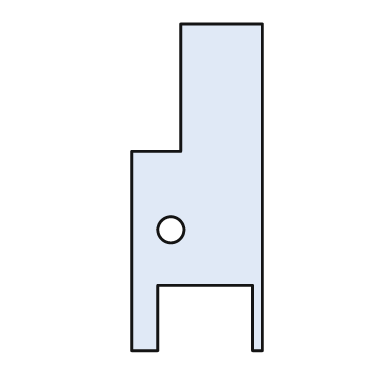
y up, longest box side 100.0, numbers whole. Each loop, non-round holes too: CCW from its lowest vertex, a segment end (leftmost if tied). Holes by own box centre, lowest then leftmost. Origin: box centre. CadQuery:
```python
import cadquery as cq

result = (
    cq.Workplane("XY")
    .moveTo(-20.0, -50.0)
    .lineTo(-12.0, -50.0)
    .lineTo(-12.0, -30.0)
    .lineTo(17.0, -30.0)
    .lineTo(17.0, -50.0)
    .lineTo(20.0, -50.0)
    .lineTo(20.0, 50.0)
    .lineTo(-5.0, 50.0)
    .lineTo(-5.0, 11.0)
    .lineTo(-20.0, 11.0)
    .close()
    .moveTo(-8.0, -13.0)
    .circle(4.0)
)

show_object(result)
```